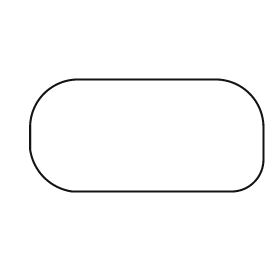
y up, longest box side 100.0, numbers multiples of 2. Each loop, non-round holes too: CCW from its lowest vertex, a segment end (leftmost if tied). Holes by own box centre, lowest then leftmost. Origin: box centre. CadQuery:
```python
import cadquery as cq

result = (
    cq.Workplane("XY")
    .moveTo(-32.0, -24.0)
    .lineTo(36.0, -24.0)
    .threePointArc((46.0, -20.0), (50.0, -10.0))
    .lineTo(50.0, 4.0)
    .threePointArc((44.0, 18.0), (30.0, 24.0))
    .lineTo(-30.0, 24.0)
    .threePointArc((-44.0, 18.0), (-50.0, 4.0))
    .lineTo(-50.0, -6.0)
    .threePointArc((-44.0, -18.0), (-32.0, -24.0))
    .close()
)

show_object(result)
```